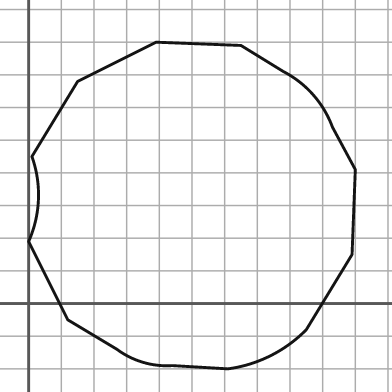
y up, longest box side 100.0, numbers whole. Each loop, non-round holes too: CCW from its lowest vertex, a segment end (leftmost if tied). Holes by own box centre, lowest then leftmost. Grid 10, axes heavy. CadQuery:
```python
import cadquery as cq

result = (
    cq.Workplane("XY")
    .moveTo(61.0, -20.0)
    .threePointArc((74.0, -16.0), (85.0, -8.0))
    .lineTo(99.0, 15.0)
    .lineTo(100.0, 41.0)
    .lineTo(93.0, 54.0)
    .threePointArc((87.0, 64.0), (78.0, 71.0))
    .lineTo(65.0, 79.0)
    .lineTo(39.0, 80.0)
    .lineTo(15.0, 68.0)
    .lineTo(1.0, 45.0)
    .threePointArc((3.0, 32.0), (0.0, 19.0))
    .lineTo(12.0, -5.0)
    .lineTo(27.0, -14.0)
    .threePointArc((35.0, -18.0), (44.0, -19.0))
    .close()
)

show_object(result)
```